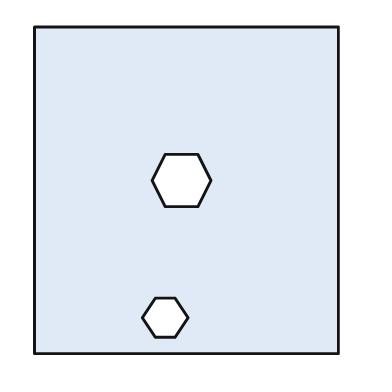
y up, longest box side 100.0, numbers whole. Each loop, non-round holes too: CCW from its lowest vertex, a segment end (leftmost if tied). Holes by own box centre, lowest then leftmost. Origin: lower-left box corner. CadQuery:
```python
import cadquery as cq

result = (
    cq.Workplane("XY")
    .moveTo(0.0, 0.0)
    .lineTo(93.0, 0.0)
    .lineTo(93.0, 100.0)
    .lineTo(0.0, 100.0)
    .close()
    .moveTo(37.0, 5.0)
    .lineTo(43.0, 5.0)
    .lineTo(47.0, 11.0)
    .lineTo(43.0, 17.0)
    .lineTo(37.0, 17.0)
    .lineTo(33.0, 11.0)
    .close()
    .moveTo(40.0, 45.0)
    .lineTo(50.0, 45.0)
    .lineTo(54.0, 53.0)
    .lineTo(50.0, 61.0)
    .lineTo(40.0, 61.0)
    .lineTo(36.0, 53.0)
    .close()
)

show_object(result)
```